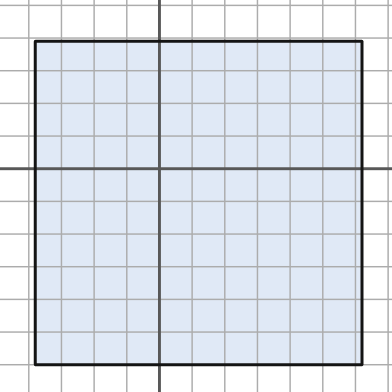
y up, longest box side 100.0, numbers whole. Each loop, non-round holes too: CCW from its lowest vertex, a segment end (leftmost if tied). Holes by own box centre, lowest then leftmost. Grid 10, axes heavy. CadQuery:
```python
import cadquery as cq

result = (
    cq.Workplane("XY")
    .moveTo(-38.0, -60.0)
    .lineTo(62.0, -60.0)
    .lineTo(62.0, 39.0)
    .lineTo(-38.0, 39.0)
    .close()
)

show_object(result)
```